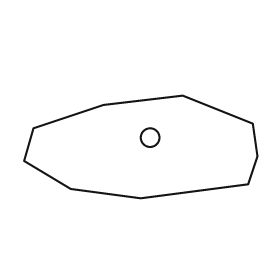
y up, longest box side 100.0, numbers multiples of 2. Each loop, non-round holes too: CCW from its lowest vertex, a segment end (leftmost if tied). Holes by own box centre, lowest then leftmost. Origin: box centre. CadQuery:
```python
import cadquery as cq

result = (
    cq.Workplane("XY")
    .moveTo(0.0, -22.0)
    .lineTo(46.0, -16.0)
    .lineTo(50.0, -4.0)
    .lineTo(48.0, 10.0)
    .lineTo(18.0, 22.0)
    .lineTo(-16.0, 18.0)
    .lineTo(-46.0, 8.0)
    .lineTo(-50.0, -6.0)
    .lineTo(-30.0, -18.0)
    .close()
    .moveTo(4.0, 4.0)
    .circle(4.0)
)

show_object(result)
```